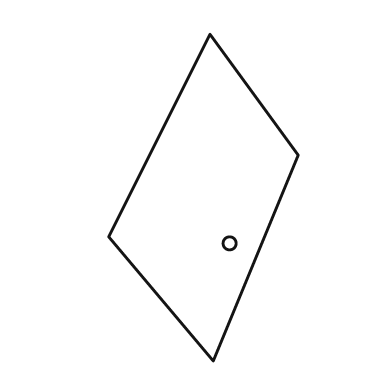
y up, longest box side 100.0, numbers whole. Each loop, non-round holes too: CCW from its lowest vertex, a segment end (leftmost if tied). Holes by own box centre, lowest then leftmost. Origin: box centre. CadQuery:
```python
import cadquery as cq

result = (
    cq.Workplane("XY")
    .moveTo(3.0, -50.0)
    .lineTo(29.0, 13.0)
    .lineTo(2.0, 50.0)
    .lineTo(-29.0, -12.0)
    .close()
    .moveTo(8.0, -14.0)
    .circle(2.0)
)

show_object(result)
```